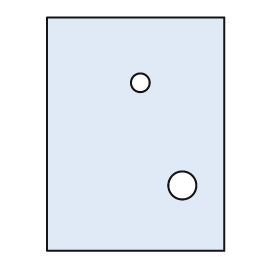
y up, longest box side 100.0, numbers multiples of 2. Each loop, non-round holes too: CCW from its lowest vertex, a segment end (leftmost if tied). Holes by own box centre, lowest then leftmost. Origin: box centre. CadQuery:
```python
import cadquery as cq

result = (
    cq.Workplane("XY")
    .moveTo(-38.0, -50.0)
    .lineTo(38.0, -50.0)
    .lineTo(38.0, 50.0)
    .lineTo(-38.0, 50.0)
    .close()
    .moveTo(20.0, -22.0)
    .circle(6.0)
    .moveTo(2.0, 22.0)
    .circle(4.0)
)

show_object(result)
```